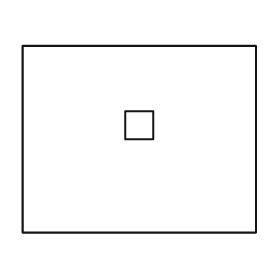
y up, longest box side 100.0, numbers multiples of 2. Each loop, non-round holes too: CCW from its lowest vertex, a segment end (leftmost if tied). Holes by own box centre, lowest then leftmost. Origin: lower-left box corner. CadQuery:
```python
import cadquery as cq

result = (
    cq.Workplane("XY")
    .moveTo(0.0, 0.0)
    .lineTo(100.0, 0.0)
    .lineTo(100.0, 80.0)
    .lineTo(0.0, 80.0)
    .close()
    .moveTo(44.0, 40.0)
    .lineTo(56.0, 40.0)
    .lineTo(56.0, 52.0)
    .lineTo(44.0, 52.0)
    .close()
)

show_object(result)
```